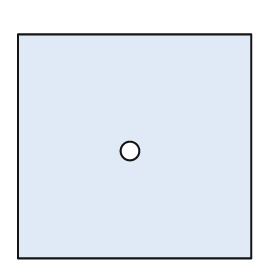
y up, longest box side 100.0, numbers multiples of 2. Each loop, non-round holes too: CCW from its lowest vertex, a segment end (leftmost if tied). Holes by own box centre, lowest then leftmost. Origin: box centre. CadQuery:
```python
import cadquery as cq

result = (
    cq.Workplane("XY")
    .moveTo(-50.0, -48.0)
    .lineTo(50.0, -48.0)
    .lineTo(50.0, 48.0)
    .lineTo(-50.0, 48.0)
    .close()
    .moveTo(-2.0, -2.0)
    .circle(4.0)
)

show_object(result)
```